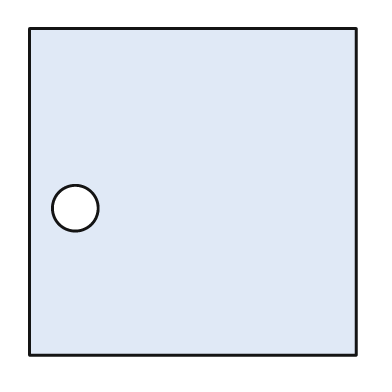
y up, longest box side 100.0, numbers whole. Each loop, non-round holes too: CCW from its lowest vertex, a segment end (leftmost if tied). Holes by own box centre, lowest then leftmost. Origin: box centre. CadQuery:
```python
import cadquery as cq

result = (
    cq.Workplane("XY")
    .moveTo(-50.0, -50.0)
    .lineTo(50.0, -50.0)
    .lineTo(50.0, 50.0)
    .lineTo(-50.0, 50.0)
    .close()
    .moveTo(-36.0, -5.0)
    .circle(7.0)
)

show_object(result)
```